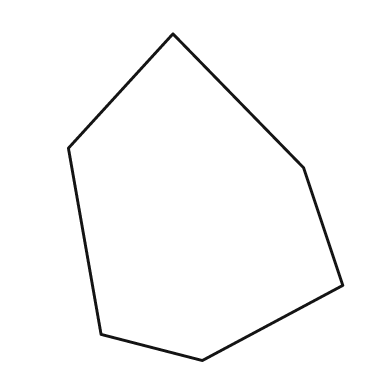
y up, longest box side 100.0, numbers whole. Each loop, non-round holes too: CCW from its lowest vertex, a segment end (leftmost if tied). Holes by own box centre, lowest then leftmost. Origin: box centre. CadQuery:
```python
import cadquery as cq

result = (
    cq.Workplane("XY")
    .moveTo(-1.0, -50.0)
    .lineTo(42.0, -27.0)
    .lineTo(30.0, 9.0)
    .lineTo(-10.0, 50.0)
    .lineTo(-42.0, 15.0)
    .lineTo(-32.0, -42.0)
    .close()
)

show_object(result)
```